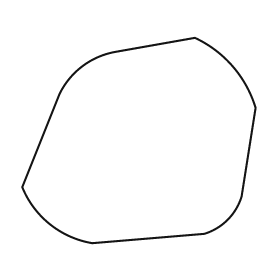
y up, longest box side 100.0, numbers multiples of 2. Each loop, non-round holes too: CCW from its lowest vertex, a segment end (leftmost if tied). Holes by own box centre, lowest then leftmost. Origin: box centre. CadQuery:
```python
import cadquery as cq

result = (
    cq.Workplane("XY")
    .moveTo(-20.0, -44.0)
    .lineTo(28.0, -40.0)
    .threePointArc((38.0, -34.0), (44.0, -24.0))
    .lineTo(50.0, 14.0)
    .threePointArc((40.0, 32.0), (24.0, 44.0))
    .lineTo(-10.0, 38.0)
    .threePointArc((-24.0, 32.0), (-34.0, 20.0))
    .lineTo(-50.0, -20.0)
    .threePointArc((-38.0, -36.0), (-20.0, -44.0))
    .close()
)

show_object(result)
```